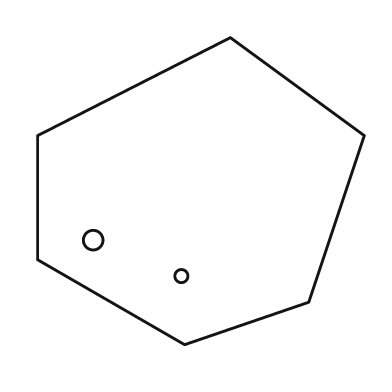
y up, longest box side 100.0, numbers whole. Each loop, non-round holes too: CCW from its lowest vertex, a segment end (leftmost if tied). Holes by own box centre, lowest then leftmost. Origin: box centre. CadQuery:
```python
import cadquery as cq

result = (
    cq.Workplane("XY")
    .moveTo(-5.0, -47.0)
    .lineTo(33.0, -34.0)
    .lineTo(50.0, 17.0)
    .lineTo(9.0, 47.0)
    .lineTo(-50.0, 17.0)
    .lineTo(-50.0, -21.0)
    .close()
    .moveTo(-6.0, -26.0)
    .circle(2.0)
    .moveTo(-33.0, -15.0)
    .circle(3.0)
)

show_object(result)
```